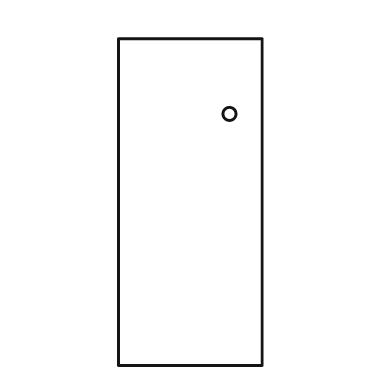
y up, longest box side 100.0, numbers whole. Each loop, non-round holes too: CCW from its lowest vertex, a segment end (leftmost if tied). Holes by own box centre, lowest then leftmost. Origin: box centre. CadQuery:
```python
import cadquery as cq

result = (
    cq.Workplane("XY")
    .moveTo(-22.0, -50.0)
    .lineTo(22.0, -50.0)
    .lineTo(22.0, 50.0)
    .lineTo(-22.0, 50.0)
    .close()
    .moveTo(12.0, 27.0)
    .circle(2.0)
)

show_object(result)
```